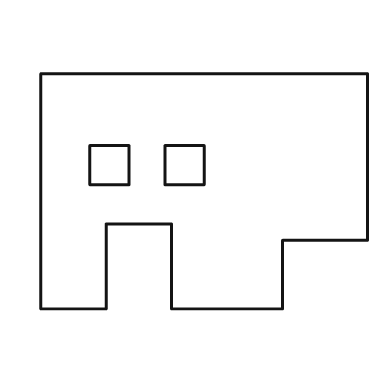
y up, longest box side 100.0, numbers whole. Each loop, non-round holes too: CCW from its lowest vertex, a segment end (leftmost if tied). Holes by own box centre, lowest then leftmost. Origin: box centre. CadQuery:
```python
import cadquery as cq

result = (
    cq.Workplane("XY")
    .moveTo(-50.0, -36.0)
    .lineTo(-30.0, -36.0)
    .lineTo(-30.0, -10.0)
    .lineTo(-10.0, -10.0)
    .lineTo(-10.0, -36.0)
    .lineTo(24.0, -36.0)
    .lineTo(24.0, -15.0)
    .lineTo(50.0, -15.0)
    .lineTo(50.0, 36.0)
    .lineTo(-50.0, 36.0)
    .close()
    .moveTo(-35.0, 2.0)
    .lineTo(-23.0, 2.0)
    .lineTo(-23.0, 14.0)
    .lineTo(-35.0, 14.0)
    .close()
    .moveTo(-12.0, 2.0)
    .lineTo(0.0, 2.0)
    .lineTo(0.0, 14.0)
    .lineTo(-12.0, 14.0)
    .close()
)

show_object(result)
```